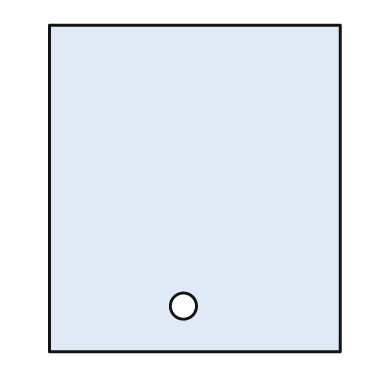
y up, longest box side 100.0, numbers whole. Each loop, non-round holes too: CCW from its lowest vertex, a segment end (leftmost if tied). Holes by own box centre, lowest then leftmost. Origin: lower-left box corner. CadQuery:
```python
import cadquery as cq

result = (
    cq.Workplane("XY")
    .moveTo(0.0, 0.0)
    .lineTo(89.0, 0.0)
    .lineTo(89.0, 100.0)
    .lineTo(0.0, 100.0)
    .close()
    .moveTo(41.0, 14.0)
    .circle(4.0)
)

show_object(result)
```